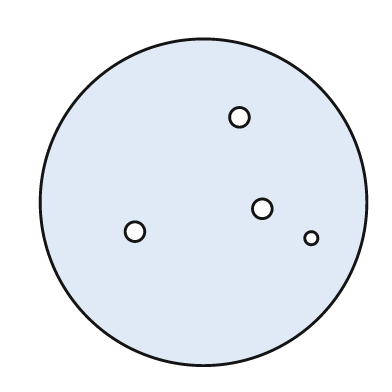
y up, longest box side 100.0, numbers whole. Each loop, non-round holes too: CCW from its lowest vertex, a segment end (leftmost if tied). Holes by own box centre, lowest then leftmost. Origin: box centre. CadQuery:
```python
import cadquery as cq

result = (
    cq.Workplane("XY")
    .moveTo(0.0, 0.0)
    .circle(50.0)
    .moveTo(33.0, -11.0)
    .circle(2.0)
    .moveTo(-21.0, -9.0)
    .circle(3.0)
    .moveTo(18.0, -2.0)
    .circle(3.0)
    .moveTo(11.0, 26.0)
    .circle(3.0)
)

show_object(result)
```